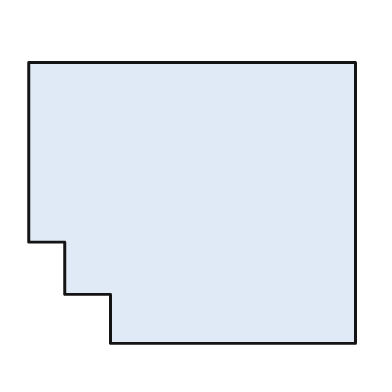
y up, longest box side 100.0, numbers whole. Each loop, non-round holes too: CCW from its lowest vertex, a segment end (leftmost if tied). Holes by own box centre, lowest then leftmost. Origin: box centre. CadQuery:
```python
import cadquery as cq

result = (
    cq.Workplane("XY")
    .moveTo(-25.0, -43.0)
    .lineTo(50.0, -43.0)
    .lineTo(50.0, 43.0)
    .lineTo(-50.0, 43.0)
    .lineTo(-50.0, -12.0)
    .lineTo(-39.0, -12.0)
    .lineTo(-39.0, -28.0)
    .lineTo(-25.0, -28.0)
    .close()
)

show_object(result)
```